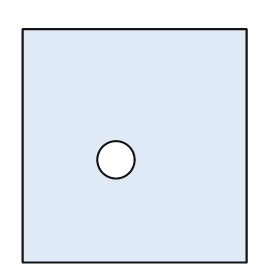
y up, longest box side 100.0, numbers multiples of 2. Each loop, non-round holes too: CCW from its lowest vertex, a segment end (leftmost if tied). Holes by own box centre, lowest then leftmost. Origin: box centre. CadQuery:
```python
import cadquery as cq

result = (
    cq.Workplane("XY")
    .moveTo(-48.0, -50.0)
    .lineTo(48.0, -50.0)
    .lineTo(48.0, 50.0)
    .lineTo(-48.0, 50.0)
    .close()
    .moveTo(-8.0, -6.0)
    .circle(8.0)
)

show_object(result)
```